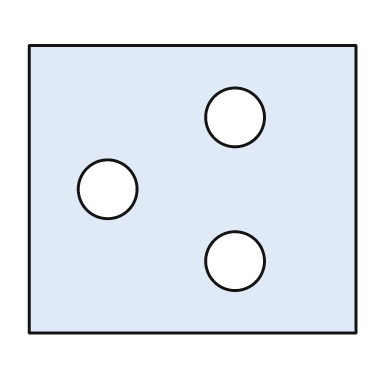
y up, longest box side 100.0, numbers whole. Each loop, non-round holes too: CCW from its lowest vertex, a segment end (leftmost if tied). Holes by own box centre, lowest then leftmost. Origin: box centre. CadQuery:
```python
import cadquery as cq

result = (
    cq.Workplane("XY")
    .moveTo(-50.0, -44.0)
    .lineTo(50.0, -44.0)
    .lineTo(50.0, 44.0)
    .lineTo(-50.0, 44.0)
    .close()
    .moveTo(13.0, -22.0)
    .circle(9.0)
    .moveTo(-26.0, 0.0)
    .circle(9.0)
    .moveTo(13.0, 22.0)
    .circle(9.0)
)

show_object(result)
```